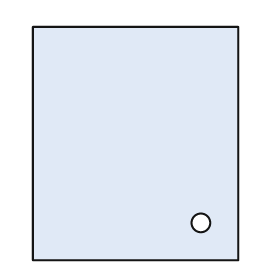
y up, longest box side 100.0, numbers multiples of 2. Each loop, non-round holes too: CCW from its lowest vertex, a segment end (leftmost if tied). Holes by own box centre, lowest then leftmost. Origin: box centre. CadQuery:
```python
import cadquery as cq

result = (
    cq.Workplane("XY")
    .moveTo(-44.0, -50.0)
    .lineTo(44.0, -50.0)
    .lineTo(44.0, 50.0)
    .lineTo(-44.0, 50.0)
    .close()
    .moveTo(28.0, -34.0)
    .circle(4.0)
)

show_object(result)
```